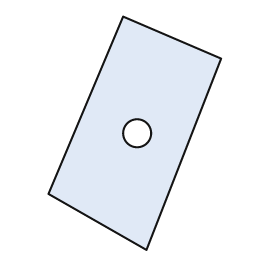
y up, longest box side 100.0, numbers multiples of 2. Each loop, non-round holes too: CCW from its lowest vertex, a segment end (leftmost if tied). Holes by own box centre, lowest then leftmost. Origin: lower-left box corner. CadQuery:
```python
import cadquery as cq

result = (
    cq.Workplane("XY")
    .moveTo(42.0, 0.0)
    .lineTo(74.0, 82.0)
    .lineTo(32.0, 100.0)
    .lineTo(0.0, 24.0)
    .close()
    .moveTo(38.0, 50.0)
    .circle(6.0)
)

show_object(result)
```